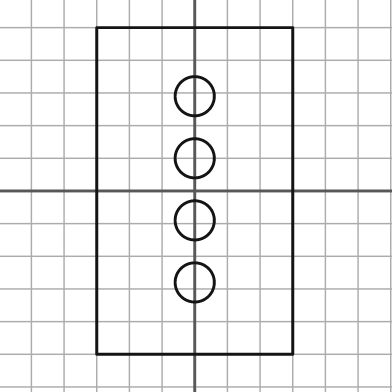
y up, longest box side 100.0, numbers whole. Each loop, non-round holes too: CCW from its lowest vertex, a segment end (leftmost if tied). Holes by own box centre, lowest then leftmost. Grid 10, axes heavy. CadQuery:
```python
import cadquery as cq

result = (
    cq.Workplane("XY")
    .moveTo(-30.0, -50.0)
    .lineTo(30.0, -50.0)
    .lineTo(30.0, 50.0)
    .lineTo(-30.0, 50.0)
    .close()
    .moveTo(0.0, -28.0)
    .circle(6.0)
    .moveTo(0.0, -9.0)
    .circle(6.0)
    .moveTo(0.0, 10.0)
    .circle(6.0)
    .moveTo(0.0, 29.0)
    .circle(6.0)
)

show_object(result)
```